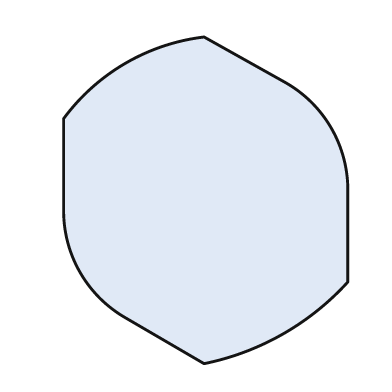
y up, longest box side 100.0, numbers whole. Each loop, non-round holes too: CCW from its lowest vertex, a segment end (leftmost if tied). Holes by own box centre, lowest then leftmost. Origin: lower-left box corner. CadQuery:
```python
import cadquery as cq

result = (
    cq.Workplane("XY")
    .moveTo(43.0, 0.0)
    .threePointArc((67.0, 9.0), (87.0, 25.0))
    .lineTo(87.0, 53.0)
    .threePointArc((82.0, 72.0), (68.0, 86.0))
    .lineTo(43.0, 100.0)
    .threePointArc((19.0, 92.0), (0.0, 75.0))
    .lineTo(0.0, 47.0)
    .threePointArc((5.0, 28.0), (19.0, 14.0))
    .close()
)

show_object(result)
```